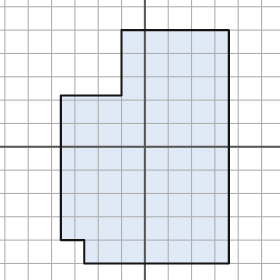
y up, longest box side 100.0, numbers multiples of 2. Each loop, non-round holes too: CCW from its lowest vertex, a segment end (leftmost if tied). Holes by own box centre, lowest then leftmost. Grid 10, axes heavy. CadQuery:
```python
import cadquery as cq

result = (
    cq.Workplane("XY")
    .moveTo(-26.0, -50.0)
    .lineTo(36.0, -50.0)
    .lineTo(36.0, 50.0)
    .lineTo(-10.0, 50.0)
    .lineTo(-10.0, 22.0)
    .lineTo(-36.0, 22.0)
    .lineTo(-36.0, -40.0)
    .lineTo(-26.0, -40.0)
    .close()
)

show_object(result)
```